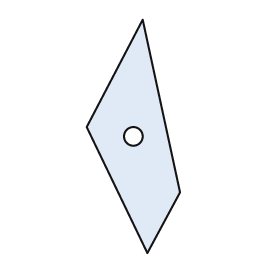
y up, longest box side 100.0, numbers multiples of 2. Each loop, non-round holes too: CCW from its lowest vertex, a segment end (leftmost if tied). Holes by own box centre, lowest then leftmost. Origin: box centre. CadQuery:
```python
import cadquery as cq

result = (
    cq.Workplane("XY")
    .moveTo(6.0, -50.0)
    .lineTo(20.0, -24.0)
    .lineTo(4.0, 50.0)
    .lineTo(-20.0, 4.0)
    .close()
    .moveTo(0.0, 0.0)
    .circle(4.0)
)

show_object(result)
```